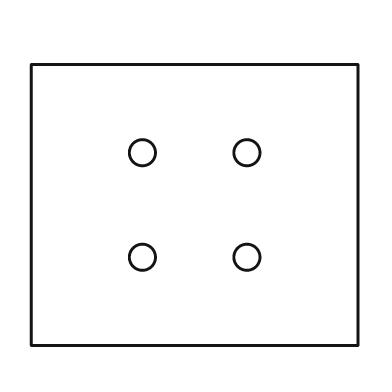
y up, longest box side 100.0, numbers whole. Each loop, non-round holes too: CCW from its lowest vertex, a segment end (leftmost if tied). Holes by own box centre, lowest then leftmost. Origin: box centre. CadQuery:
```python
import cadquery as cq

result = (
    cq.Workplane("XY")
    .moveTo(-50.0, -43.0)
    .lineTo(50.0, -43.0)
    .lineTo(50.0, 43.0)
    .lineTo(-50.0, 43.0)
    .close()
    .moveTo(-16.0, -16.0)
    .circle(4.0)
    .moveTo(16.0, -16.0)
    .circle(4.0)
    .moveTo(-16.0, 16.0)
    .circle(4.0)
    .moveTo(16.0, 16.0)
    .circle(4.0)
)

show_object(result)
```